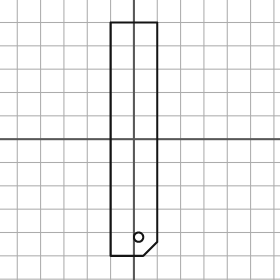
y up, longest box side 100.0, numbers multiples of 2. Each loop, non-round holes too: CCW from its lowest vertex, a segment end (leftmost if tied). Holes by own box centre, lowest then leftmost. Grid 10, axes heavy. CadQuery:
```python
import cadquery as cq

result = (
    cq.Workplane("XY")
    .moveTo(-10.0, -50.0)
    .lineTo(4.0, -50.0)
    .lineTo(10.0, -44.0)
    .lineTo(10.0, 50.0)
    .lineTo(-10.0, 50.0)
    .close()
    .moveTo(2.0, -42.0)
    .circle(2.0)
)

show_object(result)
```